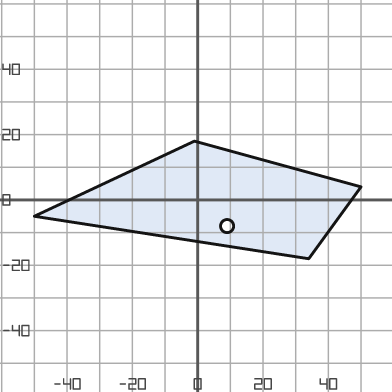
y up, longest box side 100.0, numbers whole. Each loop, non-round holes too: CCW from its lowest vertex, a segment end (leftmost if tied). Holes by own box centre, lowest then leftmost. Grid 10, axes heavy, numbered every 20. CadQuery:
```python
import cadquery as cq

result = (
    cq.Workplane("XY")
    .moveTo(34.0, -18.0)
    .lineTo(50.0, 4.0)
    .lineTo(-1.0, 18.0)
    .lineTo(-50.0, -5.0)
    .close()
    .moveTo(9.0, -8.0)
    .circle(2.0)
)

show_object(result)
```